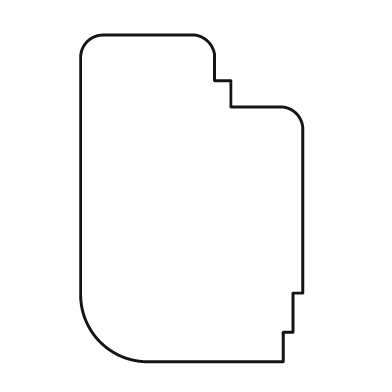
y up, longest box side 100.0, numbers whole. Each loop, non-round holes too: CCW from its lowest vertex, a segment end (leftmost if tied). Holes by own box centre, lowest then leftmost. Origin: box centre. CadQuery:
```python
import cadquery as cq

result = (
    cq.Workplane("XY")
    .moveTo(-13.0, -50.0)
    .lineTo(28.0, -50.0)
    .lineTo(28.0, -41.0)
    .lineTo(31.0, -41.0)
    .lineTo(31.0, -29.0)
    .lineTo(34.0, -29.0)
    .lineTo(34.0, 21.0)
    .threePointArc((32.0, 26.0), (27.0, 28.0))
    .lineTo(12.0, 28.0)
    .lineTo(12.0, 36.0)
    .lineTo(7.0, 36.0)
    .lineTo(7.0, 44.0)
    .threePointArc((5.0, 48.0), (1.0, 50.0))
    .lineTo(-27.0, 50.0)
    .threePointArc((-32.0, 48.0), (-34.0, 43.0))
    .lineTo(-34.0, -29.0)
    .threePointArc((-28.0, -44.0), (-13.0, -50.0))
    .close()
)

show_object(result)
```